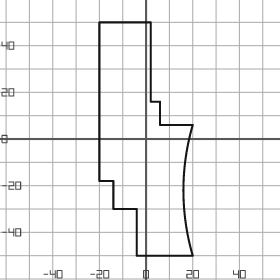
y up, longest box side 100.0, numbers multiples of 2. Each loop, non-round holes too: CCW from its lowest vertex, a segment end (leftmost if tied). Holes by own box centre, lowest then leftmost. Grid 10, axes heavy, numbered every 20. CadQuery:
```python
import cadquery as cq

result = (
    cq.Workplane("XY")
    .moveTo(-4.0, -50.0)
    .lineTo(20.0, -50.0)
    .threePointArc((16.0, -22.0), (20.0, 6.0))
    .lineTo(6.0, 6.0)
    .lineTo(6.0, 16.0)
    .lineTo(2.0, 16.0)
    .lineTo(2.0, 50.0)
    .lineTo(-20.0, 50.0)
    .lineTo(-20.0, -18.0)
    .lineTo(-14.0, -18.0)
    .lineTo(-14.0, -30.0)
    .lineTo(-4.0, -30.0)
    .close()
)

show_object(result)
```